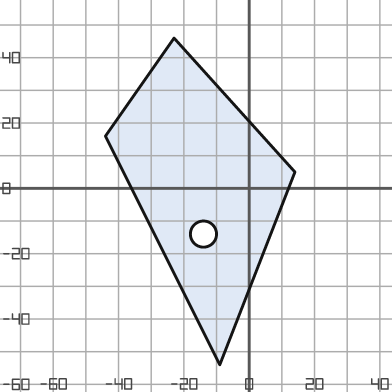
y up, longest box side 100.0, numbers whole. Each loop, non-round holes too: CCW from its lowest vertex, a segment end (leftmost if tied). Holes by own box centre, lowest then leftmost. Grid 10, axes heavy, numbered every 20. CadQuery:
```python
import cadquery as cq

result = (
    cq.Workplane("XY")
    .moveTo(-9.0, -54.0)
    .lineTo(14.0, 5.0)
    .lineTo(-23.0, 46.0)
    .lineTo(-44.0, 16.0)
    .close()
    .moveTo(-14.0, -14.0)
    .circle(4.0)
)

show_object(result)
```